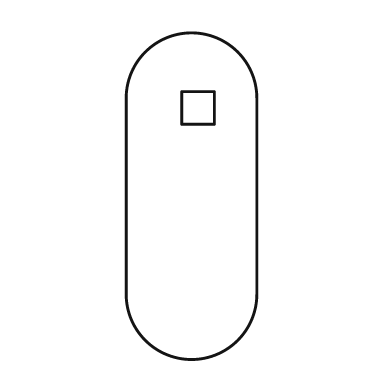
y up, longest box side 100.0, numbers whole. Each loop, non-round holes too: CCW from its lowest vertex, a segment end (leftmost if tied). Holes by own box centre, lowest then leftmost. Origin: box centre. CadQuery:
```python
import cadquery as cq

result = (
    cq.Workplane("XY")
    .moveTo(-20.0, -30.0)
    .threePointArc((0.0, -50.0), (20.0, -30.0))
    .lineTo(20.0, 30.0)
    .threePointArc((0.0, 50.0), (-20.0, 30.0))
    .close()
    .moveTo(-3.0, 22.0)
    .lineTo(7.0, 22.0)
    .lineTo(7.0, 32.0)
    .lineTo(-3.0, 32.0)
    .close()
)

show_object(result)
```